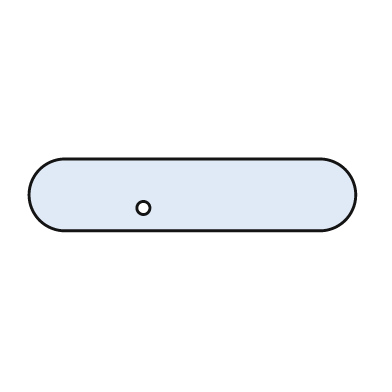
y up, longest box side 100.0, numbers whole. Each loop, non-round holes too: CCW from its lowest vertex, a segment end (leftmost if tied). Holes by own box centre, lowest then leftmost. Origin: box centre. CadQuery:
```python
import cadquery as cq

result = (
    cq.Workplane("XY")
    .moveTo(-39.0, -11.0)
    .lineTo(39.0, -11.0)
    .threePointArc((50.0, 0.0), (39.0, 11.0))
    .lineTo(-39.0, 11.0)
    .threePointArc((-50.0, 0.0), (-39.0, -11.0))
    .close()
    .moveTo(-15.0, -4.0)
    .circle(2.0)
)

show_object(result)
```